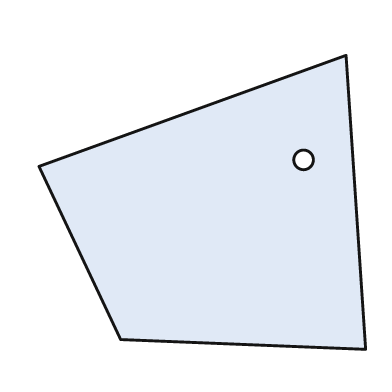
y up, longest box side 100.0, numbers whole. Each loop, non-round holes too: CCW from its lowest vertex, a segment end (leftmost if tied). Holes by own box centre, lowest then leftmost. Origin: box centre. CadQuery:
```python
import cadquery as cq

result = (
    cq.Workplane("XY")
    .moveTo(50.0, -45.0)
    .lineTo(44.0, 45.0)
    .lineTo(-50.0, 11.0)
    .lineTo(-25.0, -42.0)
    .close()
    .moveTo(31.0, 13.0)
    .circle(3.0)
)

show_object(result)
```